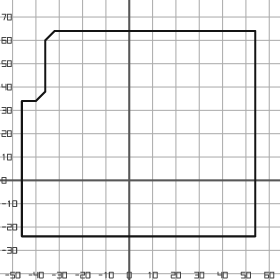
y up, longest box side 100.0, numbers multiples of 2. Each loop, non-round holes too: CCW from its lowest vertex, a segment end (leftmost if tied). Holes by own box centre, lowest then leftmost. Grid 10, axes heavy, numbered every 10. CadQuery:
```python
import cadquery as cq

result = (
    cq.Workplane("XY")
    .moveTo(-46.0, -24.0)
    .lineTo(54.0, -24.0)
    .lineTo(54.0, 64.0)
    .lineTo(-32.0, 64.0)
    .lineTo(-36.0, 60.0)
    .lineTo(-36.0, 38.0)
    .lineTo(-40.0, 34.0)
    .lineTo(-46.0, 34.0)
    .close()
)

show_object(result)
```